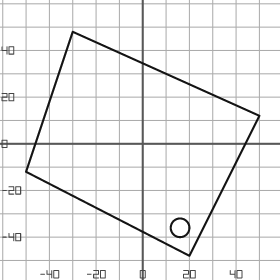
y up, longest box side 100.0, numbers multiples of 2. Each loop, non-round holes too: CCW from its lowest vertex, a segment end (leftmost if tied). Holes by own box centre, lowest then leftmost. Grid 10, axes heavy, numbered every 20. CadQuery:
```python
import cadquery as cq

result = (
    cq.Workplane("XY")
    .moveTo(20.0, -48.0)
    .lineTo(50.0, 12.0)
    .lineTo(-30.0, 48.0)
    .lineTo(-50.0, -12.0)
    .close()
    .moveTo(16.0, -36.0)
    .circle(4.0)
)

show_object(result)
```